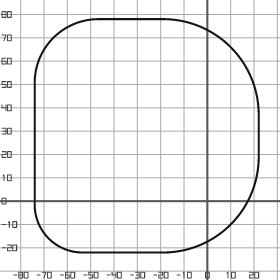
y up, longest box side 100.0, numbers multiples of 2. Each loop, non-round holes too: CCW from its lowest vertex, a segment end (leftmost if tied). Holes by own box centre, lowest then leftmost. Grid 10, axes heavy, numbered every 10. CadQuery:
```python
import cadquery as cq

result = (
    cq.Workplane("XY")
    .moveTo(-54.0, -22.0)
    .lineTo(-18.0, -22.0)
    .threePointArc((10.0, -10.0), (22.0, 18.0))
    .lineTo(22.0, 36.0)
    .threePointArc((10.0, 66.0), (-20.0, 78.0))
    .lineTo(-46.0, 78.0)
    .threePointArc((-66.0, 70.0), (-74.0, 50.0))
    .lineTo(-74.0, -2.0)
    .threePointArc((-68.0, -16.0), (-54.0, -22.0))
    .close()
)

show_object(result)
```